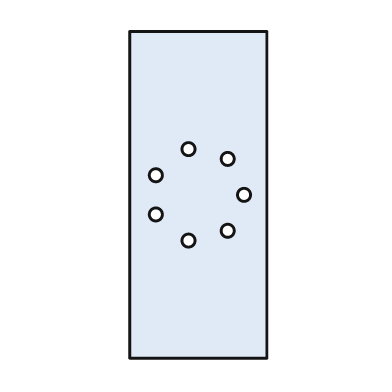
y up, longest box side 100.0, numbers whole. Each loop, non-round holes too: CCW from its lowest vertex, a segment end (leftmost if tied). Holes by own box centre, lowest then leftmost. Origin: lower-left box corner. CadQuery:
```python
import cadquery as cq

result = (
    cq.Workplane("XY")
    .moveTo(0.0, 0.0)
    .lineTo(42.0, 0.0)
    .lineTo(42.0, 100.0)
    .lineTo(0.0, 100.0)
    .close()
    .moveTo(18.0, 36.0)
    .circle(2.0)
    .moveTo(30.0, 39.0)
    .circle(2.0)
    .moveTo(8.0, 44.0)
    .circle(2.0)
    .moveTo(35.0, 50.0)
    .circle(2.0)
    .moveTo(8.0, 56.0)
    .circle(2.0)
    .moveTo(30.0, 61.0)
    .circle(2.0)
    .moveTo(18.0, 64.0)
    .circle(2.0)
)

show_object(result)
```